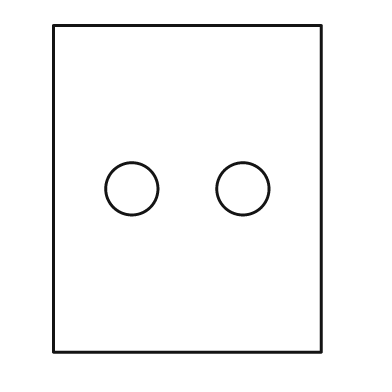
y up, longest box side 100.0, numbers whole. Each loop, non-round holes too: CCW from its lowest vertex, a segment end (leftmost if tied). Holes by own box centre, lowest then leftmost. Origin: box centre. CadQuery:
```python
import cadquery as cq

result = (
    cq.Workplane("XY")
    .moveTo(-41.0, -50.0)
    .lineTo(41.0, -50.0)
    .lineTo(41.0, 50.0)
    .lineTo(-41.0, 50.0)
    .close()
    .moveTo(-17.0, 0.0)
    .circle(8.0)
    .moveTo(17.0, 0.0)
    .circle(8.0)
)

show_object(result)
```